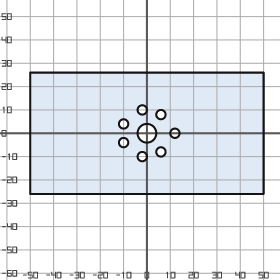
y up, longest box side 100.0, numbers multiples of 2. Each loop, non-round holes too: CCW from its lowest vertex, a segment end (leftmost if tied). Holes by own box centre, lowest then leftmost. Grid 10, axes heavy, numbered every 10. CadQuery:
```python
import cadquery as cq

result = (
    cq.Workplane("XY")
    .moveTo(-50.0, -26.0)
    .lineTo(50.0, -26.0)
    .lineTo(50.0, 26.0)
    .lineTo(-50.0, 26.0)
    .close()
    .moveTo(-2.0, -10.0)
    .circle(2.0)
    .moveTo(6.0, -8.0)
    .circle(2.0)
    .moveTo(-10.0, -4.0)
    .circle(2.0)
    .moveTo(0.0, 0.0)
    .circle(4.0)
    .moveTo(12.0, 0.0)
    .circle(2.0)
    .moveTo(-10.0, 4.0)
    .circle(2.0)
    .moveTo(6.0, 8.0)
    .circle(2.0)
    .moveTo(-2.0, 10.0)
    .circle(2.0)
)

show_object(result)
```